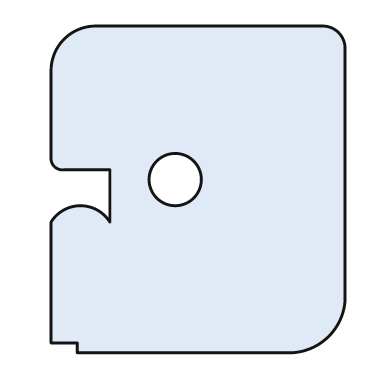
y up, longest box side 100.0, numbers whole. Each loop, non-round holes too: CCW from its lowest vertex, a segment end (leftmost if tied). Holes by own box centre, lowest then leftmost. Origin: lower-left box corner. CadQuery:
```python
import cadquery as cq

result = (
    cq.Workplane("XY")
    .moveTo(8.0, 0.0)
    .lineTo(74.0, 0.0)
    .threePointArc((85.0, 5.0), (90.0, 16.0))
    .lineTo(90.0, 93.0)
    .threePointArc((88.0, 98.0), (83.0, 100.0))
    .lineTo(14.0, 100.0)
    .threePointArc((4.0, 96.0), (0.0, 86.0))
    .lineTo(0.0, 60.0)
    .threePointArc((1.0, 57.0), (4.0, 56.0))
    .lineTo(18.0, 56.0)
    .lineTo(18.0, 40.0)
    .threePointArc((9.0, 45.0), (0.0, 40.0))
    .lineTo(0.0, 3.0)
    .lineTo(8.0, 3.0)
    .close()
    .moveTo(38.0, 53.0)
    .circle(8.0)
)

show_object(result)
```